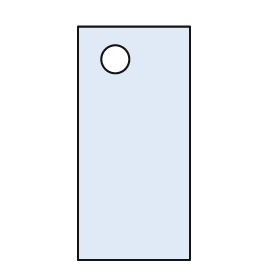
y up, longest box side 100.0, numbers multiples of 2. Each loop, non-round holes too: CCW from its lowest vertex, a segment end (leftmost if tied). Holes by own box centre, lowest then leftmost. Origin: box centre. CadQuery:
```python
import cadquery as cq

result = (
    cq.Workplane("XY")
    .moveTo(-24.0, -50.0)
    .lineTo(24.0, -50.0)
    .lineTo(24.0, 50.0)
    .lineTo(-24.0, 50.0)
    .close()
    .moveTo(-8.0, 36.0)
    .circle(6.0)
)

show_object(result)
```